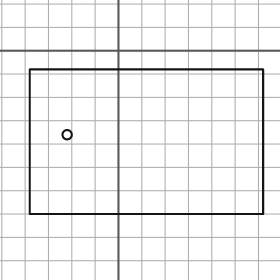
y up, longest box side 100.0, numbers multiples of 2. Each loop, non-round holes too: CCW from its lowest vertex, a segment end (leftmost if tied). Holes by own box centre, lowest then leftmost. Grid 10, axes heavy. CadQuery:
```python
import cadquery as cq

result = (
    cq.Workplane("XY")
    .moveTo(-38.0, -70.0)
    .lineTo(62.0, -70.0)
    .lineTo(62.0, -8.0)
    .lineTo(-38.0, -8.0)
    .close()
    .moveTo(-22.0, -36.0)
    .circle(2.0)
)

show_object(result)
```